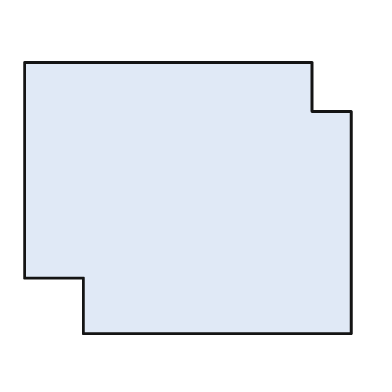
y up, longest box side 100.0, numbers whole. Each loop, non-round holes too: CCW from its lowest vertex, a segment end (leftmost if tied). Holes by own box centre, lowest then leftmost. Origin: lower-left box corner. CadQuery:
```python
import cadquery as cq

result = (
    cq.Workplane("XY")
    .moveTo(18.0, 0.0)
    .lineTo(100.0, 0.0)
    .lineTo(100.0, 68.0)
    .lineTo(88.0, 68.0)
    .lineTo(88.0, 83.0)
    .lineTo(0.0, 83.0)
    .lineTo(0.0, 17.0)
    .lineTo(18.0, 17.0)
    .close()
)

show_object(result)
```